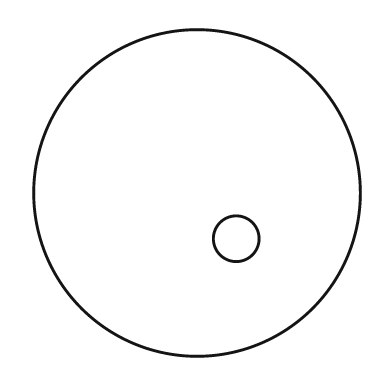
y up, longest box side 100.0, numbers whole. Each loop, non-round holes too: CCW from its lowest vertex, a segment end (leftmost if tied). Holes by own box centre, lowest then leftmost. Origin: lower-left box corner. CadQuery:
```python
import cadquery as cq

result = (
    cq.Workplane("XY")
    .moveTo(50.0, 50.0)
    .circle(50.0)
    .moveTo(62.0, 36.0)
    .circle(7.0)
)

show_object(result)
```